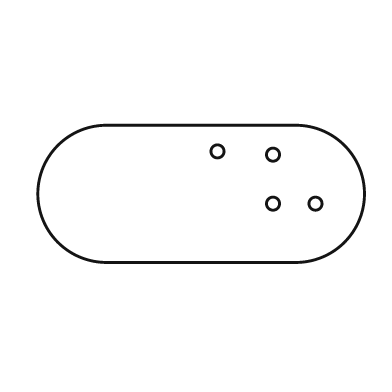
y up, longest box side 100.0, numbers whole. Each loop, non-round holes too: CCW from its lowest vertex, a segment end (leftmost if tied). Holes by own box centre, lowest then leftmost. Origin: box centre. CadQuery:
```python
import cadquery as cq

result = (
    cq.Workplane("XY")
    .moveTo(-29.0, -21.0)
    .lineTo(29.0, -21.0)
    .threePointArc((50.0, 0.0), (29.0, 21.0))
    .lineTo(-29.0, 21.0)
    .threePointArc((-50.0, 0.0), (-29.0, -21.0))
    .close()
    .moveTo(22.0, -3.0)
    .circle(2.0)
    .moveTo(35.0, -3.0)
    .circle(2.0)
    .moveTo(22.0, 12.0)
    .circle(2.0)
    .moveTo(5.0, 13.0)
    .circle(2.0)
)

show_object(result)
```